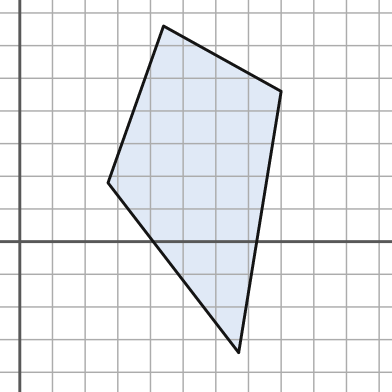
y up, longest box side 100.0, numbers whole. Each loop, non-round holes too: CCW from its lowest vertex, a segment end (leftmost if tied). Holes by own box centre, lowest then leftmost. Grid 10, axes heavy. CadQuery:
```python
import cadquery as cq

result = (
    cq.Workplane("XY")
    .moveTo(67.0, -34.0)
    .lineTo(80.0, 46.0)
    .lineTo(44.0, 66.0)
    .lineTo(27.0, 18.0)
    .close()
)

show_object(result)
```